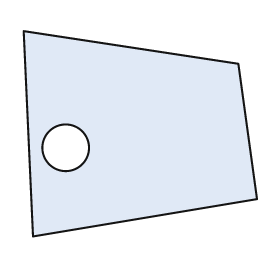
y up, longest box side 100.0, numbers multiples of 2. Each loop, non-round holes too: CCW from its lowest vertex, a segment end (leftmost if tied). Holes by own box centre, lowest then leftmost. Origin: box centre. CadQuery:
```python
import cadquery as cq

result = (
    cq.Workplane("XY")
    .moveTo(-46.0, -44.0)
    .lineTo(50.0, -28.0)
    .lineTo(42.0, 30.0)
    .lineTo(-50.0, 44.0)
    .close()
    .moveTo(-32.0, -6.0)
    .circle(10.0)
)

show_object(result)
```